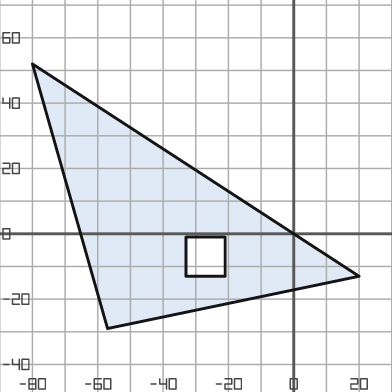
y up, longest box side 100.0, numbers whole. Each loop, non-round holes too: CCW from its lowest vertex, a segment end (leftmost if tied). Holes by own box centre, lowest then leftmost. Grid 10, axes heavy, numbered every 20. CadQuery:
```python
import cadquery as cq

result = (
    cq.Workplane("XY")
    .moveTo(-57.0, -29.0)
    .lineTo(20.0, -13.0)
    .lineTo(-80.0, 52.0)
    .close()
    .moveTo(-33.0, -13.0)
    .lineTo(-21.0, -13.0)
    .lineTo(-21.0, -1.0)
    .lineTo(-33.0, -1.0)
    .close()
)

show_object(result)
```